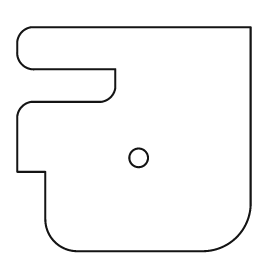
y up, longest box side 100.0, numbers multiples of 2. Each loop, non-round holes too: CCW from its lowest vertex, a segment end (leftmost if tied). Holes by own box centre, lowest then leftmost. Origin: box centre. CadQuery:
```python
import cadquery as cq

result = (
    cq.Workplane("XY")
    .moveTo(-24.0, -48.0)
    .lineTo(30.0, -48.0)
    .threePointArc((44.0, -42.0), (50.0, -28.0))
    .lineTo(50.0, 48.0)
    .lineTo(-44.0, 48.0)
    .threePointArc((-48.0, 46.0), (-50.0, 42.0))
    .lineTo(-50.0, 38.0)
    .threePointArc((-48.0, 32.0), (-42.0, 30.0))
    .lineTo(-8.0, 30.0)
    .lineTo(-8.0, 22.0)
    .threePointArc((-10.0, 18.0), (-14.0, 16.0))
    .lineTo(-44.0, 16.0)
    .threePointArc((-48.0, 14.0), (-50.0, 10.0))
    .lineTo(-50.0, -14.0)
    .lineTo(-38.0, -14.0)
    .lineTo(-38.0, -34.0)
    .threePointArc((-34.0, -44.0), (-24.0, -48.0))
    .close()
    .moveTo(2.0, -8.0)
    .circle(4.0)
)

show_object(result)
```